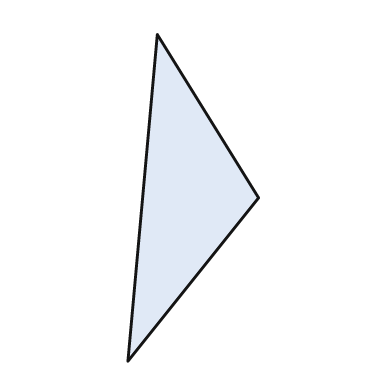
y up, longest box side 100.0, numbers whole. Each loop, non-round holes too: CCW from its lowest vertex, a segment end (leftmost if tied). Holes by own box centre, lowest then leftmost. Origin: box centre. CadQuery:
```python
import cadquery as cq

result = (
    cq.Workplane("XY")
    .moveTo(-20.0, -50.0)
    .lineTo(20.0, 0.0)
    .lineTo(-11.0, 50.0)
    .close()
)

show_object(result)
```